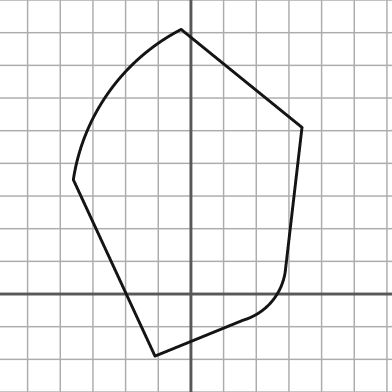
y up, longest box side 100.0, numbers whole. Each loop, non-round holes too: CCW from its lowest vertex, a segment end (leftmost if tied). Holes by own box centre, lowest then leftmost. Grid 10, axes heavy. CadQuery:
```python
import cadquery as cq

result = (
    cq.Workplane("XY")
    .moveTo(-11.0, -19.0)
    .lineTo(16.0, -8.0)
    .threePointArc((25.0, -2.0), (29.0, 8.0))
    .lineTo(34.0, 51.0)
    .lineTo(-3.0, 81.0)
    .threePointArc((-25.0, 62.0), (-36.0, 35.0))
    .close()
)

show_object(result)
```